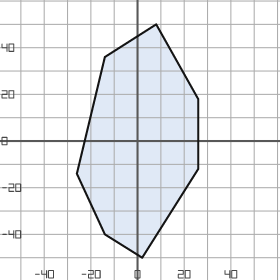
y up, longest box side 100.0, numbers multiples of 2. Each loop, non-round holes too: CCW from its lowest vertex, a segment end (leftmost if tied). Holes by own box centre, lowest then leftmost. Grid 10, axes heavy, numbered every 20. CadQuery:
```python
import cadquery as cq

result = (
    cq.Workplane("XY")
    .moveTo(2.0, -50.0)
    .lineTo(26.0, -12.0)
    .lineTo(26.0, 18.0)
    .lineTo(8.0, 50.0)
    .lineTo(-14.0, 36.0)
    .lineTo(-26.0, -14.0)
    .lineTo(-14.0, -40.0)
    .close()
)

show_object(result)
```